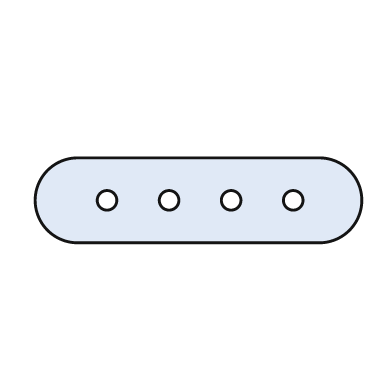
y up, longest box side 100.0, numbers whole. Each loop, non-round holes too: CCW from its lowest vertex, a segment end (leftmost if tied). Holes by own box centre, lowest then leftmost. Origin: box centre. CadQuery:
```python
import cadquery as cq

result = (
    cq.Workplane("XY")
    .moveTo(-37.0, -13.0)
    .lineTo(37.0, -13.0)
    .threePointArc((50.0, 0.0), (37.0, 13.0))
    .lineTo(-37.0, 13.0)
    .threePointArc((-50.0, 0.0), (-37.0, -13.0))
    .close()
    .moveTo(-28.0, 0.0)
    .circle(3.0)
    .moveTo(-9.0, 0.0)
    .circle(3.0)
    .moveTo(10.0, 0.0)
    .circle(3.0)
    .moveTo(29.0, 0.0)
    .circle(3.0)
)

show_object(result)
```